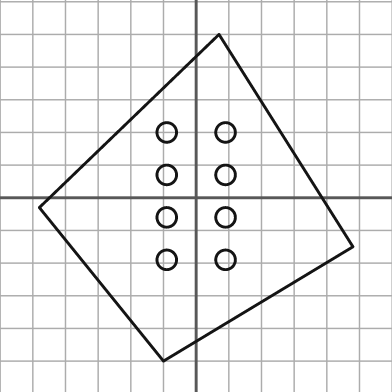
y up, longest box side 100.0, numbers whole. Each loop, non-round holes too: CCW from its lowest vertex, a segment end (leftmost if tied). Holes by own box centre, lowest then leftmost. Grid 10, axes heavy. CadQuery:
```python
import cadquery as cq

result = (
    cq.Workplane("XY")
    .moveTo(-10.0, -50.0)
    .lineTo(48.0, -15.0)
    .lineTo(7.0, 50.0)
    .lineTo(-48.0, -3.0)
    .close()
    .moveTo(-9.0, -19.0)
    .circle(3.0)
    .moveTo(9.0, -19.0)
    .circle(3.0)
    .moveTo(-9.0, -6.0)
    .circle(3.0)
    .moveTo(9.0, -6.0)
    .circle(3.0)
    .moveTo(-9.0, 7.0)
    .circle(3.0)
    .moveTo(9.0, 7.0)
    .circle(3.0)
    .moveTo(-9.0, 20.0)
    .circle(3.0)
    .moveTo(9.0, 20.0)
    .circle(3.0)
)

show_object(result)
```